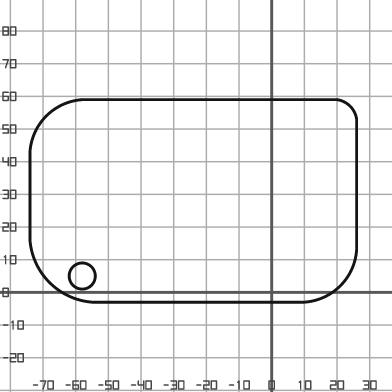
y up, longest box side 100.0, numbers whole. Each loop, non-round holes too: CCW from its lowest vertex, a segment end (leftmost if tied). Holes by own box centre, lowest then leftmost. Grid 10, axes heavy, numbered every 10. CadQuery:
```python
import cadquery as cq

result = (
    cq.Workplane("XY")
    .moveTo(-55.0, -3.0)
    .lineTo(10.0, -3.0)
    .threePointArc((21.0, 2.0), (26.0, 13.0))
    .lineTo(26.0, 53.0)
    .threePointArc((24.0, 57.0), (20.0, 59.0))
    .lineTo(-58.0, 59.0)
    .threePointArc((-69.0, 54.0), (-74.0, 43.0))
    .lineTo(-74.0, 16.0)
    .threePointArc((-68.0, 3.0), (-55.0, -3.0))
    .close()
    .moveTo(-58.0, 5.0)
    .circle(4.0)
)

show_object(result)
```